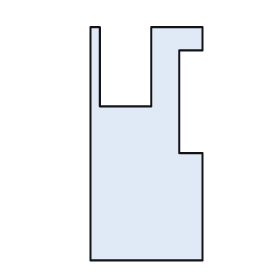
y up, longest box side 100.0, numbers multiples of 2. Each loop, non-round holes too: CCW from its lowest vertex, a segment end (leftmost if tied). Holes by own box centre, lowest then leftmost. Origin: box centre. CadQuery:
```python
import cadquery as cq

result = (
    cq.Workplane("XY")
    .moveTo(-24.0, -50.0)
    .lineTo(24.0, -50.0)
    .lineTo(24.0, -4.0)
    .lineTo(14.0, -4.0)
    .lineTo(14.0, 40.0)
    .lineTo(24.0, 40.0)
    .lineTo(24.0, 50.0)
    .lineTo(2.0, 50.0)
    .lineTo(2.0, 16.0)
    .lineTo(-20.0, 16.0)
    .lineTo(-20.0, 50.0)
    .lineTo(-24.0, 50.0)
    .close()
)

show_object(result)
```